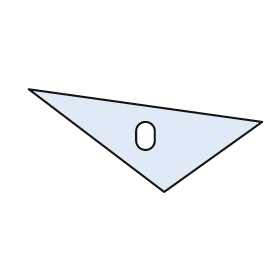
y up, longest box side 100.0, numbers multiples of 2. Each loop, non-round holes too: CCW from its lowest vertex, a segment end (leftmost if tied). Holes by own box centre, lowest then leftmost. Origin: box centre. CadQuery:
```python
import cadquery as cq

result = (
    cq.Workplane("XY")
    .moveTo(8.0, -22.0)
    .lineTo(50.0, 8.0)
    .lineTo(-50.0, 22.0)
    .close()
    .moveTo(-4.0, 0.0)
    .threePointArc((0.0, -4.0), (4.0, 0.0))
    .lineTo(4.0, 4.0)
    .threePointArc((0.0, 8.0), (-4.0, 4.0))
    .close()
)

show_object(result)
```